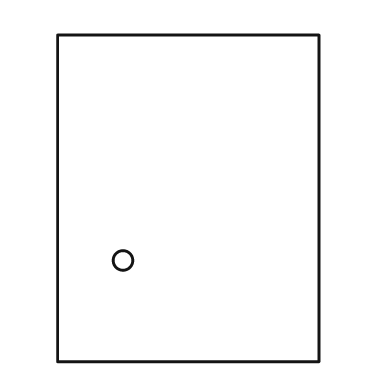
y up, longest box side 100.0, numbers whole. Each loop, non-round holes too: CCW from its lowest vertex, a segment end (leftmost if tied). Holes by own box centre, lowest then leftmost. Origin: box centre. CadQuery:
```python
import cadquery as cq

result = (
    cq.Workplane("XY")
    .moveTo(-40.0, -50.0)
    .lineTo(40.0, -50.0)
    .lineTo(40.0, 50.0)
    .lineTo(-40.0, 50.0)
    .close()
    .moveTo(-20.0, -19.0)
    .circle(3.0)
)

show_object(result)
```